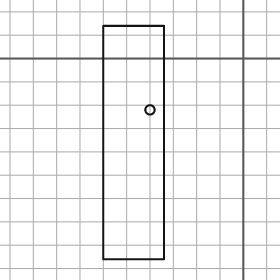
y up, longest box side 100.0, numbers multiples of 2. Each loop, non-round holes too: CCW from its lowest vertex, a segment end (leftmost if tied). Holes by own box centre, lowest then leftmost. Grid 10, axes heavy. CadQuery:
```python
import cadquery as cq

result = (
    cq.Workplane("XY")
    .moveTo(-60.0, -86.0)
    .lineTo(-34.0, -86.0)
    .lineTo(-34.0, 14.0)
    .lineTo(-60.0, 14.0)
    .close()
    .moveTo(-40.0, -22.0)
    .circle(2.0)
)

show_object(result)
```